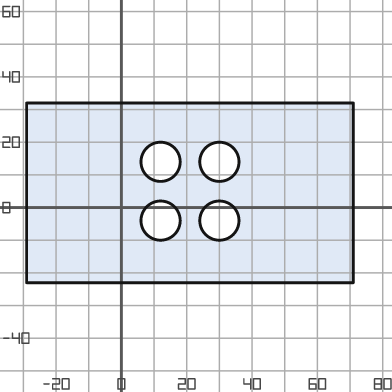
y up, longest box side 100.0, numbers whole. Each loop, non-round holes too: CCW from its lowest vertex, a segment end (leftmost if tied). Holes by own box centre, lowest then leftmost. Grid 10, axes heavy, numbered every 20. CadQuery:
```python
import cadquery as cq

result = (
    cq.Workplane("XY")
    .moveTo(-29.0, -23.0)
    .lineTo(71.0, -23.0)
    .lineTo(71.0, 32.0)
    .lineTo(-29.0, 32.0)
    .close()
    .moveTo(12.0, -4.0)
    .circle(6.0)
    .moveTo(30.0, -4.0)
    .circle(6.0)
    .moveTo(12.0, 14.0)
    .circle(6.0)
    .moveTo(30.0, 14.0)
    .circle(6.0)
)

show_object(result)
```